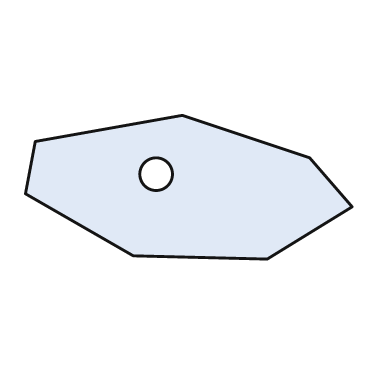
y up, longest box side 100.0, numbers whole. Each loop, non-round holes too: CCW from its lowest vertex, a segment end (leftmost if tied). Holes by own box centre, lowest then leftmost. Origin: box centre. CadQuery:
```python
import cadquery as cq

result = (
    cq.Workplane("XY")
    .moveTo(24.0, -22.0)
    .lineTo(50.0, -6.0)
    .lineTo(37.0, 9.0)
    .lineTo(-2.0, 22.0)
    .lineTo(-47.0, 14.0)
    .lineTo(-50.0, -2.0)
    .lineTo(-17.0, -21.0)
    .close()
    .moveTo(-10.0, 4.0)
    .circle(5.0)
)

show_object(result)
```